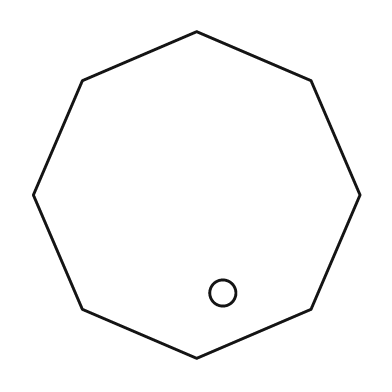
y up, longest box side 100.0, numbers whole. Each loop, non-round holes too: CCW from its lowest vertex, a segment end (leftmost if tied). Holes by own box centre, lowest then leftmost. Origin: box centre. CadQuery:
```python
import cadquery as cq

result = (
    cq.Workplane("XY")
    .moveTo(0.0, -50.0)
    .lineTo(35.0, -35.0)
    .lineTo(50.0, 0.0)
    .lineTo(35.0, 35.0)
    .lineTo(0.0, 50.0)
    .lineTo(-35.0, 35.0)
    .lineTo(-50.0, 0.0)
    .lineTo(-35.0, -35.0)
    .close()
    .moveTo(8.0, -30.0)
    .circle(4.0)
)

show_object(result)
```